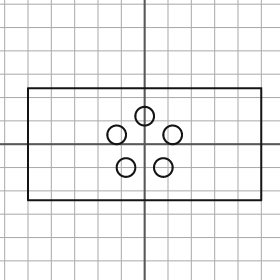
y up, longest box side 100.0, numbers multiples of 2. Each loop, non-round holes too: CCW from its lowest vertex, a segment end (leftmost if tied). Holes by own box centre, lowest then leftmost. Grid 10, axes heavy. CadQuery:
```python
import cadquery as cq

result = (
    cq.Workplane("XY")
    .moveTo(-50.0, -24.0)
    .lineTo(50.0, -24.0)
    .lineTo(50.0, 24.0)
    .lineTo(-50.0, 24.0)
    .close()
    .moveTo(-8.0, -10.0)
    .circle(4.0)
    .moveTo(8.0, -10.0)
    .circle(4.0)
    .moveTo(-12.0, 4.0)
    .circle(4.0)
    .moveTo(12.0, 4.0)
    .circle(4.0)
    .moveTo(0.0, 12.0)
    .circle(4.0)
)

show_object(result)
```